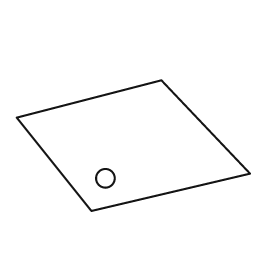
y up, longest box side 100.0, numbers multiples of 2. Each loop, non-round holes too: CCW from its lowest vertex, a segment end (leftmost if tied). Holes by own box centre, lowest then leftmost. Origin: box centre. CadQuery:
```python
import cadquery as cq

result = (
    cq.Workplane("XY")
    .moveTo(-18.0, -28.0)
    .lineTo(50.0, -12.0)
    .lineTo(12.0, 28.0)
    .lineTo(-50.0, 12.0)
    .close()
    .moveTo(-12.0, -14.0)
    .circle(4.0)
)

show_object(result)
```